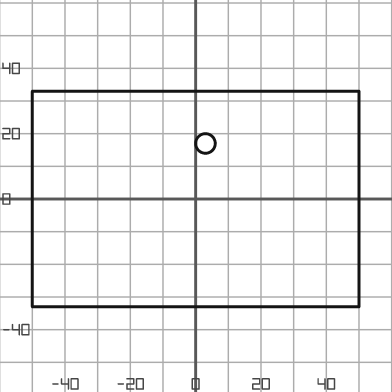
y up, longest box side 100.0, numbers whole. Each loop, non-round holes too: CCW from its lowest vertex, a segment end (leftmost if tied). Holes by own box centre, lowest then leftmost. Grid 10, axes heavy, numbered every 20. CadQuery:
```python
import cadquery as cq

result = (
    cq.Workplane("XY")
    .moveTo(-50.0, -33.0)
    .lineTo(50.0, -33.0)
    .lineTo(50.0, 33.0)
    .lineTo(-50.0, 33.0)
    .close()
    .moveTo(3.0, 17.0)
    .circle(3.0)
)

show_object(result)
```